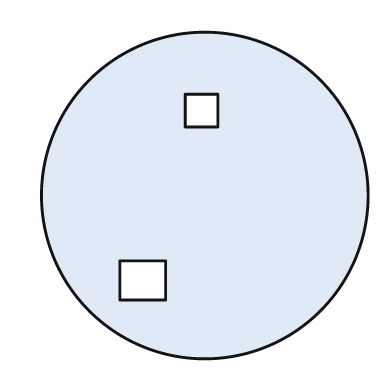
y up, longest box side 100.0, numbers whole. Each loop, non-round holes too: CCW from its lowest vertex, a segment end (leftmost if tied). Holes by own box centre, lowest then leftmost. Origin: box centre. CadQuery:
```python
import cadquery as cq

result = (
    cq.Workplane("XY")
    .moveTo(0.0, 0.0)
    .circle(50.0)
    .moveTo(-26.0, -32.0)
    .lineTo(-12.0, -32.0)
    .lineTo(-12.0, -20.0)
    .lineTo(-26.0, -20.0)
    .close()
    .moveTo(-6.0, 21.0)
    .lineTo(4.0, 21.0)
    .lineTo(4.0, 31.0)
    .lineTo(-6.0, 31.0)
    .close()
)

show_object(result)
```